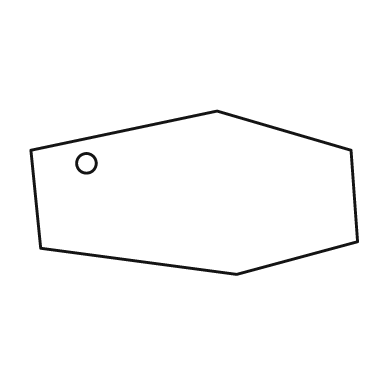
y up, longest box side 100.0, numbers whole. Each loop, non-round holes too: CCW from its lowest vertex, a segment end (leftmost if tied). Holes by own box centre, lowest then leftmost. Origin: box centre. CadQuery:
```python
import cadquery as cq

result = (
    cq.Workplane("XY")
    .moveTo(13.0, -25.0)
    .lineTo(50.0, -15.0)
    .lineTo(48.0, 13.0)
    .lineTo(7.0, 25.0)
    .lineTo(-50.0, 13.0)
    .lineTo(-47.0, -17.0)
    .close()
    .moveTo(-33.0, 9.0)
    .circle(3.0)
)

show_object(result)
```